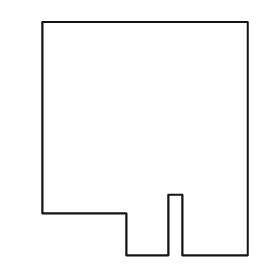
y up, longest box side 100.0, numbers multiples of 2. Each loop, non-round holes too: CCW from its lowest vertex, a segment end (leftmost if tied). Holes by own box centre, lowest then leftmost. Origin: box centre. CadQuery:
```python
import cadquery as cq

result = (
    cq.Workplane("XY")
    .moveTo(-8.0, -50.0)
    .lineTo(10.0, -50.0)
    .lineTo(10.0, -24.0)
    .lineTo(16.0, -24.0)
    .lineTo(16.0, -50.0)
    .lineTo(44.0, -50.0)
    .lineTo(44.0, 50.0)
    .lineTo(-44.0, 50.0)
    .lineTo(-44.0, -32.0)
    .lineTo(-8.0, -32.0)
    .close()
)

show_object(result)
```